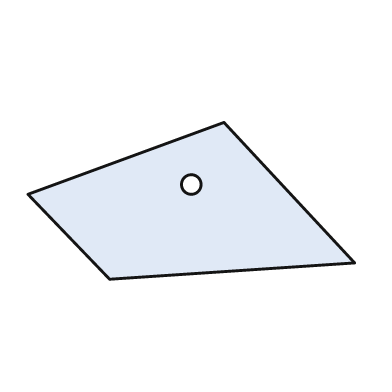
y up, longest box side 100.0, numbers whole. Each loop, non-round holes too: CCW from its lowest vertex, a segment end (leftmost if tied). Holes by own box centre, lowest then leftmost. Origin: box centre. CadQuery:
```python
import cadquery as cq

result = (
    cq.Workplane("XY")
    .moveTo(-25.0, -24.0)
    .lineTo(50.0, -19.0)
    .lineTo(10.0, 24.0)
    .lineTo(-50.0, 2.0)
    .close()
    .moveTo(0.0, 5.0)
    .circle(3.0)
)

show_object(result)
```